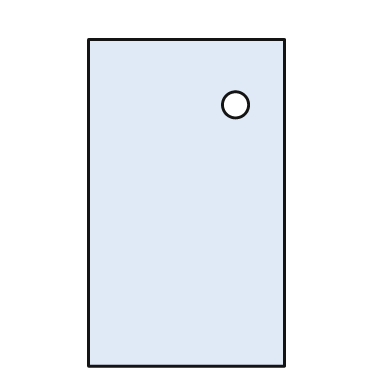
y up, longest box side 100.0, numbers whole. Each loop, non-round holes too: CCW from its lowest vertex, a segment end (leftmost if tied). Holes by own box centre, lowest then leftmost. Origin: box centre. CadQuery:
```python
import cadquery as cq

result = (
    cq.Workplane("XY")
    .moveTo(-30.0, -50.0)
    .lineTo(30.0, -50.0)
    .lineTo(30.0, 50.0)
    .lineTo(-30.0, 50.0)
    .close()
    .moveTo(15.0, 30.0)
    .circle(4.0)
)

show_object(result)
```